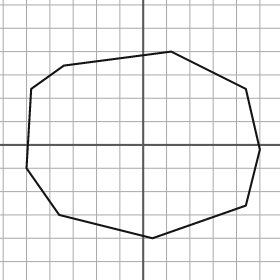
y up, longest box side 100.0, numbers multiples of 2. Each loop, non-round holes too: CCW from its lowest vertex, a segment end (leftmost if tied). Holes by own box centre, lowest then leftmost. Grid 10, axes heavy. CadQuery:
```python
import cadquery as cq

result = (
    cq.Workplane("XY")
    .moveTo(4.0, -40.0)
    .lineTo(44.0, -26.0)
    .lineTo(50.0, -2.0)
    .lineTo(44.0, 24.0)
    .lineTo(12.0, 40.0)
    .lineTo(-34.0, 34.0)
    .lineTo(-48.0, 24.0)
    .lineTo(-50.0, -10.0)
    .lineTo(-36.0, -30.0)
    .close()
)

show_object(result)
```